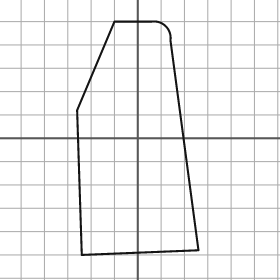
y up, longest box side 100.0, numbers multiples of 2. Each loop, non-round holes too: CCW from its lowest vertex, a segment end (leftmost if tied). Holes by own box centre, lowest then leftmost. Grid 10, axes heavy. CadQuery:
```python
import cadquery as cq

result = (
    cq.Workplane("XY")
    .moveTo(-24.0, -50.0)
    .lineTo(26.0, -48.0)
    .lineTo(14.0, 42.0)
    .threePointArc((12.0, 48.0), (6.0, 50.0))
    .lineTo(-10.0, 50.0)
    .lineTo(-26.0, 12.0)
    .close()
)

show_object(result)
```